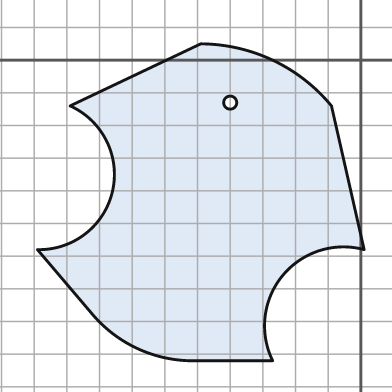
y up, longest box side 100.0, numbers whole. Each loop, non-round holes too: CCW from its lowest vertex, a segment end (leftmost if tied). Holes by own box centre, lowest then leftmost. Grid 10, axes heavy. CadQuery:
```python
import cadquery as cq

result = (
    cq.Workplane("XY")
    .moveTo(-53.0, -92.0)
    .lineTo(-27.0, -92.0)
    .threePointArc((-24.0, -66.0), (1.0, -58.0))
    .lineTo(-9.0, -14.0)
    .threePointArc((-27.0, 0.0), (-49.0, 5.0))
    .lineTo(-89.0, -14.0)
    .threePointArc((-76.0, -40.0), (-99.0, -58.0))
    .lineTo(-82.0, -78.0)
    .threePointArc((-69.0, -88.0), (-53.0, -92.0))
    .close()
    .moveTo(-40.0, -13.0)
    .circle(2.0)
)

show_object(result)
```